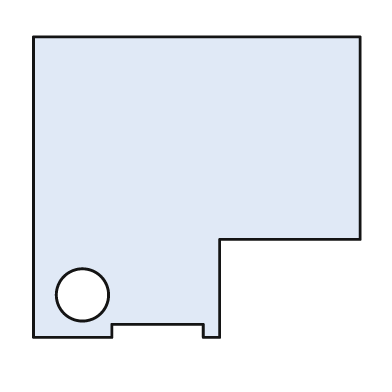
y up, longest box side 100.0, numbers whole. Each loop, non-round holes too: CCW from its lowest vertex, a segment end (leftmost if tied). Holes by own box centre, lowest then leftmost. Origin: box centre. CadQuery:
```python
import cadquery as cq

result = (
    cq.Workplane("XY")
    .moveTo(-50.0, -46.0)
    .lineTo(-26.0, -46.0)
    .lineTo(-26.0, -42.0)
    .lineTo(2.0, -42.0)
    .lineTo(2.0, -46.0)
    .lineTo(7.0, -46.0)
    .lineTo(7.0, -16.0)
    .lineTo(50.0, -16.0)
    .lineTo(50.0, 46.0)
    .lineTo(-50.0, 46.0)
    .close()
    .moveTo(-35.0, -33.0)
    .circle(8.0)
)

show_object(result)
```